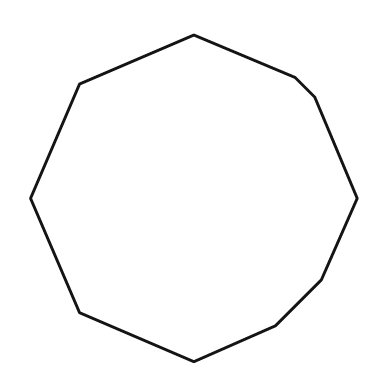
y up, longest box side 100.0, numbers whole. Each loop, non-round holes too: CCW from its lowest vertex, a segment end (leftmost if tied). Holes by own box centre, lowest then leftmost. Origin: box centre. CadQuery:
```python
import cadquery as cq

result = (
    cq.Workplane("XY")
    .moveTo(0.0, -50.0)
    .lineTo(25.0, -39.0)
    .lineTo(39.0, -25.0)
    .lineTo(50.0, 0.0)
    .lineTo(37.0, 31.0)
    .lineTo(31.0, 37.0)
    .lineTo(0.0, 50.0)
    .lineTo(-35.0, 35.0)
    .lineTo(-50.0, 0.0)
    .lineTo(-35.0, -35.0)
    .close()
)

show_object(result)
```